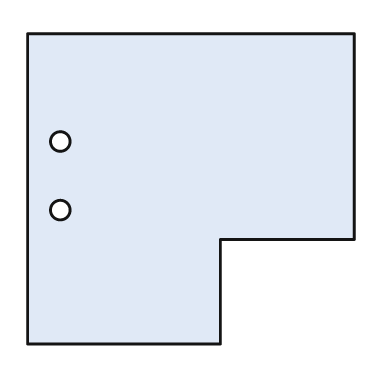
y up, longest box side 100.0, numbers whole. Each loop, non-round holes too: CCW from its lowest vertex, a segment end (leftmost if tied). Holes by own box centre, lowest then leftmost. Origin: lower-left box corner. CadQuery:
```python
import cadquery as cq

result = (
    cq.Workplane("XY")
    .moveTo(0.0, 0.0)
    .lineTo(59.0, 0.0)
    .lineTo(59.0, 32.0)
    .lineTo(100.0, 32.0)
    .lineTo(100.0, 95.0)
    .lineTo(0.0, 95.0)
    .close()
    .moveTo(10.0, 41.0)
    .circle(3.0)
    .moveTo(10.0, 62.0)
    .circle(3.0)
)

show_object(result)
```